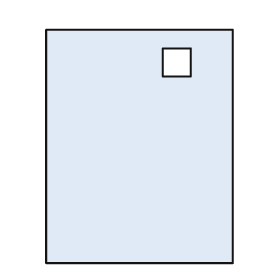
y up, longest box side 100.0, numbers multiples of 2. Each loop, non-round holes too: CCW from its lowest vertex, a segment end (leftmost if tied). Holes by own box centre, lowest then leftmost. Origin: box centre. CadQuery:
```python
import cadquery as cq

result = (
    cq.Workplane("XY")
    .moveTo(-40.0, -50.0)
    .lineTo(40.0, -50.0)
    .lineTo(40.0, 50.0)
    .lineTo(-40.0, 50.0)
    .close()
    .moveTo(10.0, 30.0)
    .lineTo(22.0, 30.0)
    .lineTo(22.0, 42.0)
    .lineTo(10.0, 42.0)
    .close()
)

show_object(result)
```